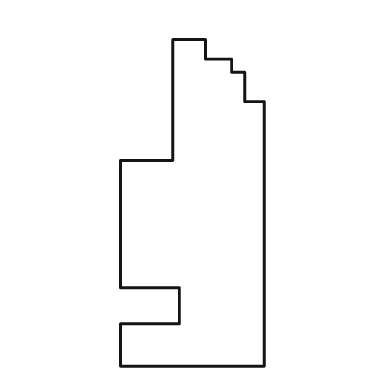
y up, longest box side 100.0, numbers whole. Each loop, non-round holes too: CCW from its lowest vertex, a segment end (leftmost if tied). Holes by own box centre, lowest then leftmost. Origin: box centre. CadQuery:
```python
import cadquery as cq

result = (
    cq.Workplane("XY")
    .moveTo(-22.0, -50.0)
    .lineTo(22.0, -50.0)
    .lineTo(22.0, 31.0)
    .lineTo(16.0, 31.0)
    .lineTo(16.0, 40.0)
    .lineTo(12.0, 40.0)
    .lineTo(12.0, 44.0)
    .lineTo(4.0, 44.0)
    .lineTo(4.0, 50.0)
    .lineTo(-6.0, 50.0)
    .lineTo(-6.0, 13.0)
    .lineTo(-22.0, 13.0)
    .lineTo(-22.0, -26.0)
    .lineTo(-4.0, -26.0)
    .lineTo(-4.0, -37.0)
    .lineTo(-22.0, -37.0)
    .close()
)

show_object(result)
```